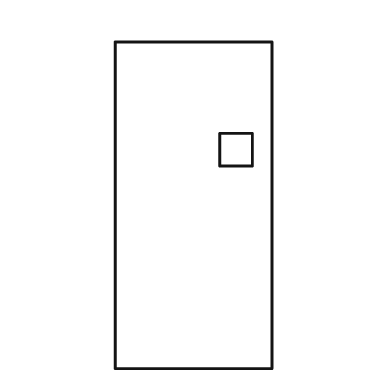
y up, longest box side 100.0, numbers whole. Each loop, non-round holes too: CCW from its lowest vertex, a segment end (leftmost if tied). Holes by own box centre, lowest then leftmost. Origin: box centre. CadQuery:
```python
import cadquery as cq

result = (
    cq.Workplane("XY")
    .moveTo(-24.0, -50.0)
    .lineTo(24.0, -50.0)
    .lineTo(24.0, 50.0)
    .lineTo(-24.0, 50.0)
    .close()
    .moveTo(8.0, 12.0)
    .lineTo(18.0, 12.0)
    .lineTo(18.0, 22.0)
    .lineTo(8.0, 22.0)
    .close()
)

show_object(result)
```